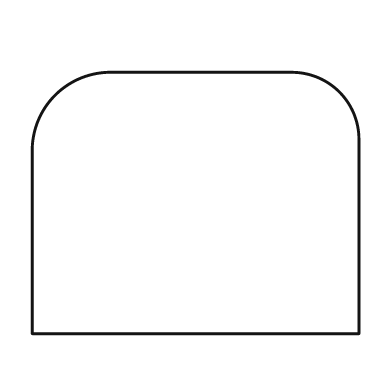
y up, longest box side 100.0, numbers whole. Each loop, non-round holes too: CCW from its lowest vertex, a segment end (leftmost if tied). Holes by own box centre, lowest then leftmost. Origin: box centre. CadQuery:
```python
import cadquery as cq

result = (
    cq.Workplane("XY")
    .moveTo(-50.0, -40.0)
    .lineTo(50.0, -40.0)
    .lineTo(50.0, 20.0)
    .threePointArc((44.0, 34.0), (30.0, 40.0))
    .lineTo(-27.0, 40.0)
    .threePointArc((-43.0, 33.0), (-50.0, 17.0))
    .close()
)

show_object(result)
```